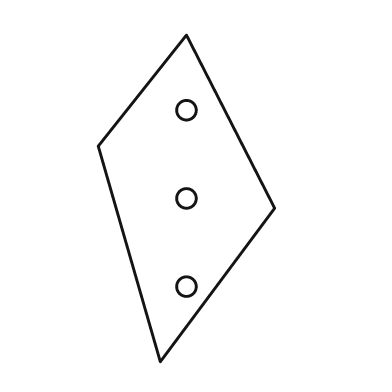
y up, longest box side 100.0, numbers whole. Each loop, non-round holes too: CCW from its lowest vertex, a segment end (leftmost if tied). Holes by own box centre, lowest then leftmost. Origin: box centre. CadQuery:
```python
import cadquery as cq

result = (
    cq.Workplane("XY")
    .moveTo(-8.0, -50.0)
    .lineTo(27.0, -3.0)
    .lineTo(0.0, 50.0)
    .lineTo(-27.0, 16.0)
    .close()
    .moveTo(0.0, -27.0)
    .circle(3.0)
    .moveTo(0.0, 0.0)
    .circle(3.0)
    .moveTo(0.0, 27.0)
    .circle(3.0)
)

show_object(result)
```